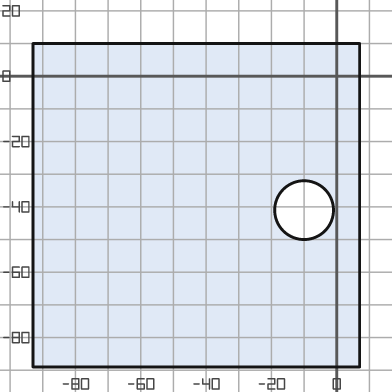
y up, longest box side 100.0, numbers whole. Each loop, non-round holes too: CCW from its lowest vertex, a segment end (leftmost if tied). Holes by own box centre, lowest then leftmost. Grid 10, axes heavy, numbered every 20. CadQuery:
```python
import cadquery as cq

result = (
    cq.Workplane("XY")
    .moveTo(-93.0, -89.0)
    .lineTo(7.0, -89.0)
    .lineTo(7.0, 10.0)
    .lineTo(-93.0, 10.0)
    .close()
    .moveTo(-10.0, -41.0)
    .circle(9.0)
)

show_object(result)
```